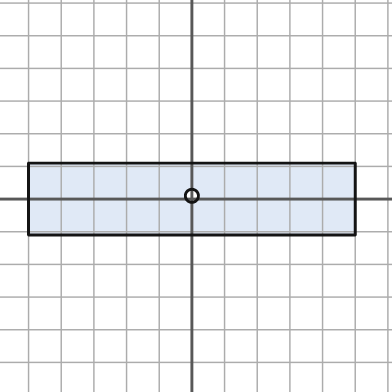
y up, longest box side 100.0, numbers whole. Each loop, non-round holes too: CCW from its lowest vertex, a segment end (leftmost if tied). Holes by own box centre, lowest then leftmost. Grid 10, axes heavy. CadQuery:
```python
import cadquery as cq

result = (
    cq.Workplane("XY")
    .moveTo(-50.0, -11.0)
    .lineTo(50.0, -11.0)
    .lineTo(50.0, 11.0)
    .lineTo(-50.0, 11.0)
    .close()
    .moveTo(0.0, 1.0)
    .circle(2.0)
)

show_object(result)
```